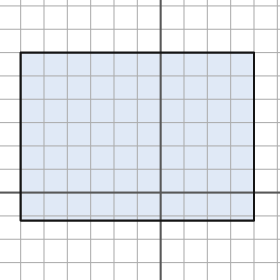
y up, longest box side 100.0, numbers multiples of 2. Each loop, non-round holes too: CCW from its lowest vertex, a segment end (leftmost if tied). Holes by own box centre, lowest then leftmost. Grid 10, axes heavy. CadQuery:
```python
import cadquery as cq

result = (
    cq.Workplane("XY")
    .moveTo(-60.0, -12.0)
    .lineTo(40.0, -12.0)
    .lineTo(40.0, 60.0)
    .lineTo(-60.0, 60.0)
    .close()
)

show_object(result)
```